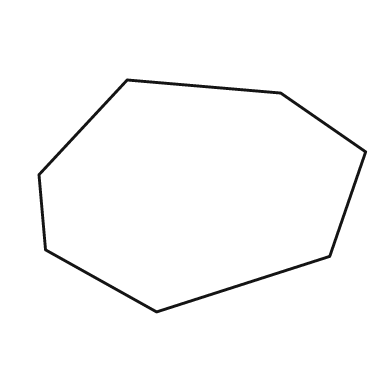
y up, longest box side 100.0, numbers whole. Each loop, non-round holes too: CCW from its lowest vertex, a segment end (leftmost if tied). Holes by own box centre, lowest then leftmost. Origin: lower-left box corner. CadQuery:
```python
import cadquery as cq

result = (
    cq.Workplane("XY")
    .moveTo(36.0, 0.0)
    .lineTo(89.0, 17.0)
    .lineTo(100.0, 49.0)
    .lineTo(74.0, 67.0)
    .lineTo(27.0, 71.0)
    .lineTo(0.0, 42.0)
    .lineTo(2.0, 19.0)
    .close()
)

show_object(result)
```